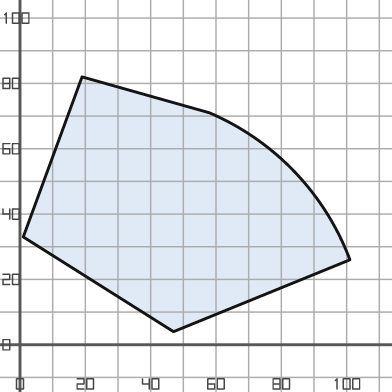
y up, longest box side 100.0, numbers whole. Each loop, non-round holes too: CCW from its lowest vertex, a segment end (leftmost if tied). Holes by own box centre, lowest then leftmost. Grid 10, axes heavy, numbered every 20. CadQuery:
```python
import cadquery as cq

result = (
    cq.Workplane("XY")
    .moveTo(47.0, 4.0)
    .lineTo(101.0, 26.0)
    .threePointArc((84.0, 53.0), (58.0, 71.0))
    .lineTo(19.0, 82.0)
    .lineTo(1.0, 33.0)
    .close()
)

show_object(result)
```